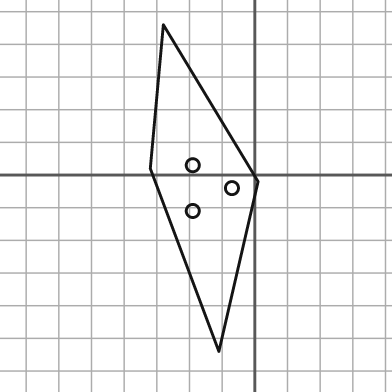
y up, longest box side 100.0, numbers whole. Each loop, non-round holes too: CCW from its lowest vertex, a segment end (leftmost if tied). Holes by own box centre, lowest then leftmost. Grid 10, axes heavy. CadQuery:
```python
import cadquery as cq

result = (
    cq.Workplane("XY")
    .moveTo(-11.0, -54.0)
    .lineTo(1.0, -2.0)
    .lineTo(-28.0, 46.0)
    .lineTo(-32.0, 2.0)
    .close()
    .moveTo(-19.0, -11.0)
    .circle(2.0)
    .moveTo(-7.0, -4.0)
    .circle(2.0)
    .moveTo(-19.0, 3.0)
    .circle(2.0)
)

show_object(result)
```